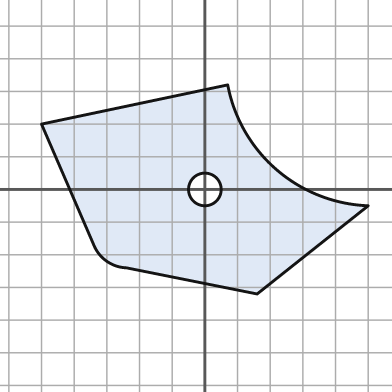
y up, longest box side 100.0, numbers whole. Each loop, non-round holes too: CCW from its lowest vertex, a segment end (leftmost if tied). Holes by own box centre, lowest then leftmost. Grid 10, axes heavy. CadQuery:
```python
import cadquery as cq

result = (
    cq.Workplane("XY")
    .moveTo(16.0, -32.0)
    .lineTo(50.0, -5.0)
    .threePointArc((22.0, 6.0), (7.0, 32.0))
    .lineTo(-50.0, 20.0)
    .lineTo(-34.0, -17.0)
    .threePointArc((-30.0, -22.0), (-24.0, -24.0))
    .close()
    .moveTo(0.0, 0.0)
    .circle(5.0)
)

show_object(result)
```